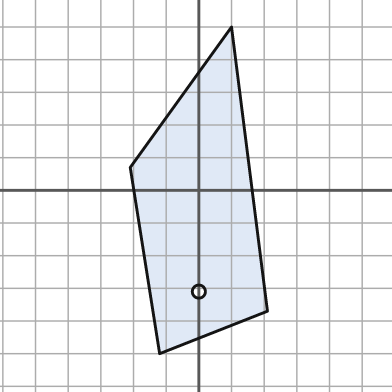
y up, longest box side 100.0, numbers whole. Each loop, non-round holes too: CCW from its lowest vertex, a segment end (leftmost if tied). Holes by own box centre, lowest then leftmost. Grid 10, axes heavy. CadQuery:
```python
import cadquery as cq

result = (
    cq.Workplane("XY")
    .moveTo(-12.0, -50.0)
    .lineTo(21.0, -37.0)
    .lineTo(10.0, 50.0)
    .lineTo(-21.0, 7.0)
    .close()
    .moveTo(0.0, -31.0)
    .circle(2.0)
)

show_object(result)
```